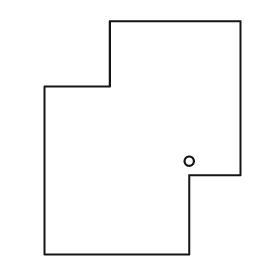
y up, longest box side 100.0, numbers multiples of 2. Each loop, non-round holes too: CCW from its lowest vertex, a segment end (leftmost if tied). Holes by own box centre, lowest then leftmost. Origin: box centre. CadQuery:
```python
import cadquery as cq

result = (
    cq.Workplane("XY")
    .moveTo(-42.0, -50.0)
    .lineTo(20.0, -50.0)
    .lineTo(20.0, -16.0)
    .lineTo(42.0, -16.0)
    .lineTo(42.0, 50.0)
    .lineTo(-14.0, 50.0)
    .lineTo(-14.0, 22.0)
    .lineTo(-42.0, 22.0)
    .close()
    .moveTo(20.0, -10.0)
    .circle(2.0)
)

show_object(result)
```